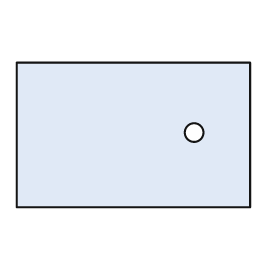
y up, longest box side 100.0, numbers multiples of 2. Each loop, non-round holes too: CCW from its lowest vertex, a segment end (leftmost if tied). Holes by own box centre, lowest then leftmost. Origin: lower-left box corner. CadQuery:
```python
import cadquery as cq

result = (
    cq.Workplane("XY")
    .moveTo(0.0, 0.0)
    .lineTo(100.0, 0.0)
    .lineTo(100.0, 62.0)
    .lineTo(0.0, 62.0)
    .close()
    .moveTo(76.0, 32.0)
    .circle(4.0)
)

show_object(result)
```